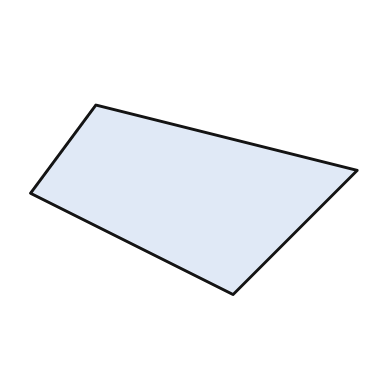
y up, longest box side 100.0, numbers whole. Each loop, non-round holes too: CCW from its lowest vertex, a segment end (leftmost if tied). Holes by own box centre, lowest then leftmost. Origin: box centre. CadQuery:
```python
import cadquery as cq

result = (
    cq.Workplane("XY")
    .moveTo(12.0, -29.0)
    .lineTo(50.0, 9.0)
    .lineTo(-30.0, 29.0)
    .lineTo(-50.0, 2.0)
    .close()
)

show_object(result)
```